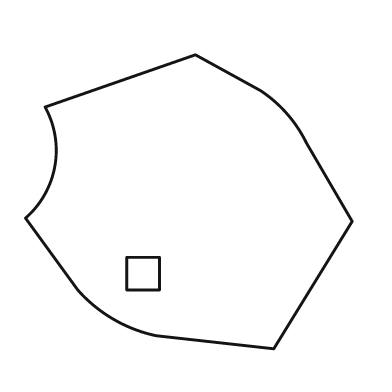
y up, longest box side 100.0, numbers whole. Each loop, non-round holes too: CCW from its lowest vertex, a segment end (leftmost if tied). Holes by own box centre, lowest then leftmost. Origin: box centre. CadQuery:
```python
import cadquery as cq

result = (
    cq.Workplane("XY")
    .moveTo(26.0, -45.0)
    .lineTo(50.0, -6.0)
    .lineTo(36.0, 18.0)
    .threePointArc((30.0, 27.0), (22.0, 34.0))
    .lineTo(2.0, 45.0)
    .lineTo(-44.0, 29.0)
    .threePointArc((-41.0, 11.0), (-50.0, -5.0))
    .lineTo(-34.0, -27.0)
    .threePointArc((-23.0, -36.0), (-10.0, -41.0))
    .close()
    .moveTo(-19.0, -27.0)
    .lineTo(-9.0, -27.0)
    .lineTo(-9.0, -17.0)
    .lineTo(-19.0, -17.0)
    .close()
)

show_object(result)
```